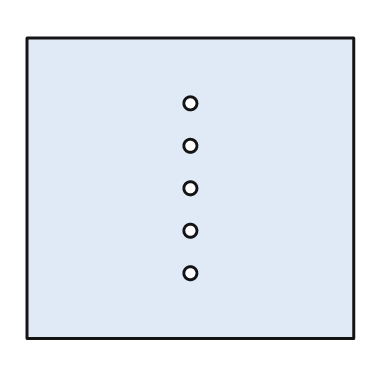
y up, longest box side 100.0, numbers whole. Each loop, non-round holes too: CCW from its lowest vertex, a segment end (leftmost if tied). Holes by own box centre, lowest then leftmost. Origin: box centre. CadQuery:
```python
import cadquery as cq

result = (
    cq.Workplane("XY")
    .moveTo(-50.0, -46.0)
    .lineTo(50.0, -46.0)
    .lineTo(50.0, 46.0)
    .lineTo(-50.0, 46.0)
    .close()
    .moveTo(0.0, -26.0)
    .circle(2.0)
    .moveTo(0.0, -13.0)
    .circle(2.0)
    .moveTo(0.0, 0.0)
    .circle(2.0)
    .moveTo(0.0, 13.0)
    .circle(2.0)
    .moveTo(0.0, 26.0)
    .circle(2.0)
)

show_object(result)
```